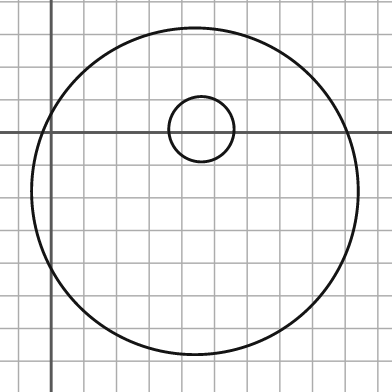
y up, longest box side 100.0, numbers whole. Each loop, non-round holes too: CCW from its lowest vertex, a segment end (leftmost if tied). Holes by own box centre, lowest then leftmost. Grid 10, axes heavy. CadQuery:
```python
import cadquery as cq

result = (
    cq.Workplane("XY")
    .moveTo(44.0, -18.0)
    .circle(50.0)
    .moveTo(46.0, 1.0)
    .circle(10.0)
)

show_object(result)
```